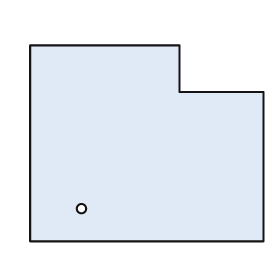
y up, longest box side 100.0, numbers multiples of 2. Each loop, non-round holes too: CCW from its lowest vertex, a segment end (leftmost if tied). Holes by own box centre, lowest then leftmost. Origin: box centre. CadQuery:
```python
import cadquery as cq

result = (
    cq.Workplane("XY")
    .moveTo(-50.0, -42.0)
    .lineTo(50.0, -42.0)
    .lineTo(50.0, 22.0)
    .lineTo(14.0, 22.0)
    .lineTo(14.0, 42.0)
    .lineTo(-50.0, 42.0)
    .close()
    .moveTo(-28.0, -28.0)
    .circle(2.0)
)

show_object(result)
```